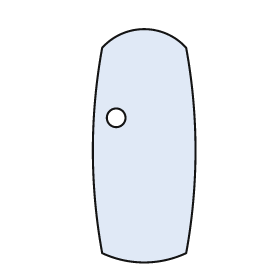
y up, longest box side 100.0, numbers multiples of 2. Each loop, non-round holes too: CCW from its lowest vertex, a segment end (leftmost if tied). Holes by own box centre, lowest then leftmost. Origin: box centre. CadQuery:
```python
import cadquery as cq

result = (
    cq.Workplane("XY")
    .moveTo(-18.0, -46.0)
    .threePointArc((0.0, -50.0), (18.0, -46.0))
    .threePointArc((22.0, -2.0), (18.0, 42.0))
    .threePointArc((0.0, 50.0), (-18.0, 42.0))
    .threePointArc((-22.0, -2.0), (-18.0, -46.0))
    .close()
    .moveTo(-12.0, 12.0)
    .circle(4.0)
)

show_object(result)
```